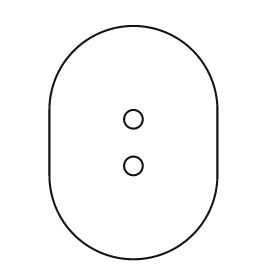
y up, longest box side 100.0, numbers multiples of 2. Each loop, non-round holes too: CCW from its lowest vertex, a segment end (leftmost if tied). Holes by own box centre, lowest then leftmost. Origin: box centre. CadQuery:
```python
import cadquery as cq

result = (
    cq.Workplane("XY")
    .moveTo(-36.0, -14.0)
    .threePointArc((0.0, -50.0), (36.0, -14.0))
    .lineTo(36.0, 14.0)
    .threePointArc((0.0, 50.0), (-36.0, 14.0))
    .close()
    .moveTo(0.0, -10.0)
    .circle(4.0)
    .moveTo(0.0, 10.0)
    .circle(4.0)
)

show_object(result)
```